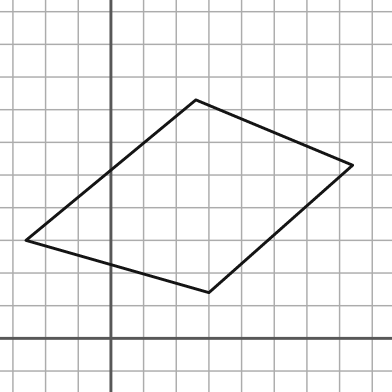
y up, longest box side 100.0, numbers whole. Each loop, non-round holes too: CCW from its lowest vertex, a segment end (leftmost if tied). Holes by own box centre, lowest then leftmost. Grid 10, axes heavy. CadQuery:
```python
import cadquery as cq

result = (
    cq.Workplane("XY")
    .moveTo(30.0, 14.0)
    .lineTo(74.0, 53.0)
    .lineTo(26.0, 73.0)
    .lineTo(-26.0, 30.0)
    .close()
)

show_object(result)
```